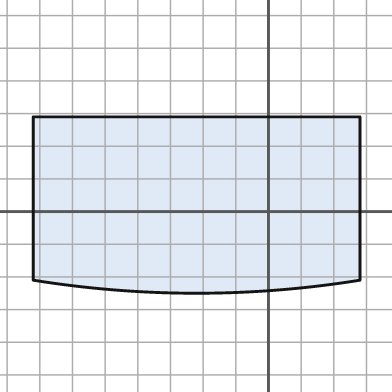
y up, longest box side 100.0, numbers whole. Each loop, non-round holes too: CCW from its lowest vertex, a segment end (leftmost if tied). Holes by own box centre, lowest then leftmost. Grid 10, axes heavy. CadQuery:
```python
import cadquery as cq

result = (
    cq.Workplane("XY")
    .moveTo(-72.0, -21.0)
    .threePointArc((-22.0, -25.0), (28.0, -21.0))
    .lineTo(28.0, 29.0)
    .lineTo(-72.0, 29.0)
    .close()
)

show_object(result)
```